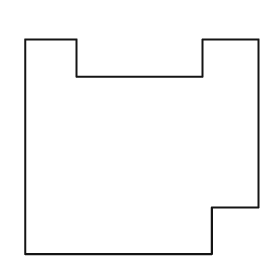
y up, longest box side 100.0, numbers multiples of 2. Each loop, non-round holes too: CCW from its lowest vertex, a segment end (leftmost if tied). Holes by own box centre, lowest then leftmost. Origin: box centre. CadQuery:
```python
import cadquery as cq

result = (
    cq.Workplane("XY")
    .moveTo(-50.0, -46.0)
    .lineTo(30.0, -46.0)
    .lineTo(30.0, -26.0)
    .lineTo(50.0, -26.0)
    .lineTo(50.0, 46.0)
    .lineTo(26.0, 46.0)
    .lineTo(26.0, 30.0)
    .lineTo(-28.0, 30.0)
    .lineTo(-28.0, 46.0)
    .lineTo(-50.0, 46.0)
    .close()
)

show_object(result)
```